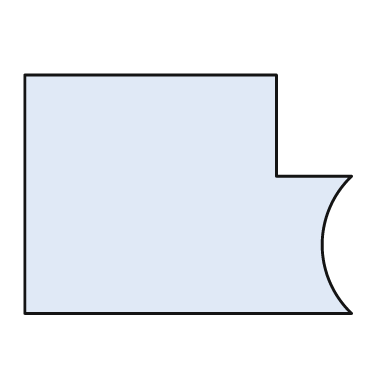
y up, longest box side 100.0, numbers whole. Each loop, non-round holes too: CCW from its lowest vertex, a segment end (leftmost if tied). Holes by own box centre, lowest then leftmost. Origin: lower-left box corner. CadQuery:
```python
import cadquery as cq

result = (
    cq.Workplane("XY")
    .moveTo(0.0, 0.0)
    .lineTo(100.0, 0.0)
    .threePointArc((91.0, 21.0), (100.0, 42.0))
    .lineTo(77.0, 42.0)
    .lineTo(77.0, 73.0)
    .lineTo(0.0, 73.0)
    .close()
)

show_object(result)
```